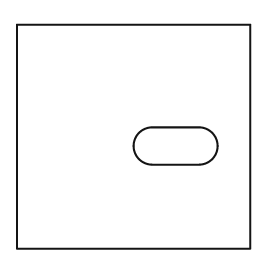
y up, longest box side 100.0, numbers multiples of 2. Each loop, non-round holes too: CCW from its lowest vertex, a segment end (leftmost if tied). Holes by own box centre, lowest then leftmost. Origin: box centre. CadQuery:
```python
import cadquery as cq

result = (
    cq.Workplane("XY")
    .moveTo(-50.0, -48.0)
    .lineTo(50.0, -48.0)
    .lineTo(50.0, 48.0)
    .lineTo(-50.0, 48.0)
    .close()
    .moveTo(8.0, -12.0)
    .lineTo(28.0, -12.0)
    .threePointArc((36.0, -4.0), (28.0, 4.0))
    .lineTo(8.0, 4.0)
    .threePointArc((0.0, -4.0), (8.0, -12.0))
    .close()
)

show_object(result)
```